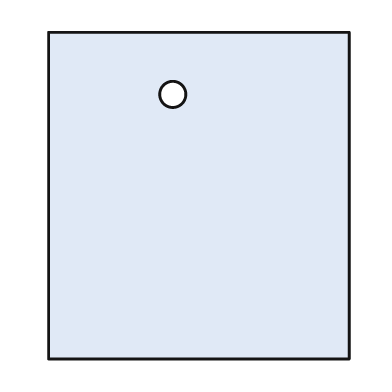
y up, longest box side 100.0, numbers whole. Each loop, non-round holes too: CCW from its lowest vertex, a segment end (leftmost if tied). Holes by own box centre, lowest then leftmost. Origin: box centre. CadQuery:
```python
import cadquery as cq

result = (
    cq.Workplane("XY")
    .moveTo(-46.0, -50.0)
    .lineTo(46.0, -50.0)
    .lineTo(46.0, 50.0)
    .lineTo(-46.0, 50.0)
    .close()
    .moveTo(-8.0, 31.0)
    .circle(4.0)
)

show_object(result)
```